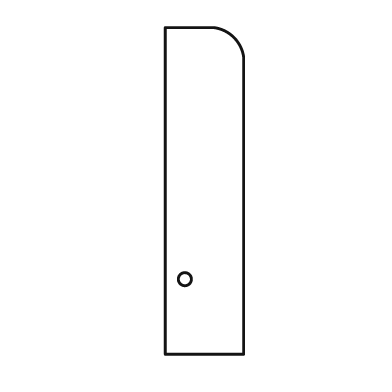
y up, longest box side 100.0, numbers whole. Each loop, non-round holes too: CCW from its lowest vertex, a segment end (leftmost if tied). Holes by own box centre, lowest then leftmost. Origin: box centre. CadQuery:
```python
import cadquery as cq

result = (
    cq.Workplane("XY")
    .moveTo(-12.0, -50.0)
    .lineTo(12.0, -50.0)
    .lineTo(12.0, 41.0)
    .threePointArc((9.0, 47.0), (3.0, 50.0))
    .lineTo(-12.0, 50.0)
    .close()
    .moveTo(-6.0, -27.0)
    .circle(2.0)
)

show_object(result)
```